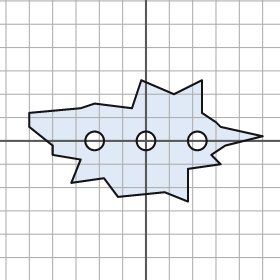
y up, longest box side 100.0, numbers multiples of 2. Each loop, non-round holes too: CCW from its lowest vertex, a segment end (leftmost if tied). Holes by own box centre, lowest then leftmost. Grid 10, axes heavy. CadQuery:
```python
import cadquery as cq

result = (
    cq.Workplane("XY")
    .moveTo(18.0, -26.0)
    .lineTo(18.0, -12.0)
    .lineTo(32.0, -10.0)
    .lineTo(28.0, -6.0)
    .lineTo(34.0, -2.0)
    .lineTo(50.0, 2.0)
    .lineTo(32.0, 6.0)
    .lineTo(30.0, 8.0)
    .lineTo(24.0, 12.0)
    .lineTo(24.0, 26.0)
    .lineTo(12.0, 20.0)
    .lineTo(-2.0, 26.0)
    .lineTo(-6.0, 14.0)
    .lineTo(-22.0, 16.0)
    .lineTo(-28.0, 14.0)
    .lineTo(-50.0, 12.0)
    .lineTo(-50.0, 6.0)
    .lineTo(-40.0, -2.0)
    .lineTo(-40.0, -6.0)
    .lineTo(-28.0, -8.0)
    .lineTo(-32.0, -18.0)
    .lineTo(-18.0, -16.0)
    .lineTo(-12.0, -24.0)
    .lineTo(8.0, -22.0)
    .close()
    .moveTo(-22.0, 0.0)
    .circle(4.0)
    .moveTo(0.0, 0.0)
    .circle(4.0)
    .moveTo(22.0, 0.0)
    .circle(4.0)
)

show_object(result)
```